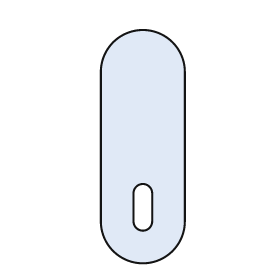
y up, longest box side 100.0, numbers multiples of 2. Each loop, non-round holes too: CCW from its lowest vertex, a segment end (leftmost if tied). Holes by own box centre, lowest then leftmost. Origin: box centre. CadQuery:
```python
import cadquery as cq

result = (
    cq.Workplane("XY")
    .moveTo(-18.0, -32.0)
    .threePointArc((0.0, -50.0), (18.0, -32.0))
    .lineTo(18.0, 32.0)
    .threePointArc((0.0, 50.0), (-18.0, 32.0))
    .close()
    .moveTo(-4.0, -32.0)
    .threePointArc((0.0, -36.0), (4.0, -32.0))
    .lineTo(4.0, -20.0)
    .threePointArc((0.0, -16.0), (-4.0, -20.0))
    .close()
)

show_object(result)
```